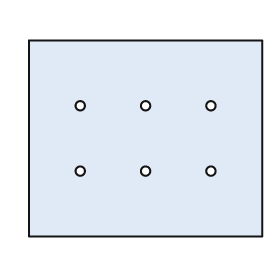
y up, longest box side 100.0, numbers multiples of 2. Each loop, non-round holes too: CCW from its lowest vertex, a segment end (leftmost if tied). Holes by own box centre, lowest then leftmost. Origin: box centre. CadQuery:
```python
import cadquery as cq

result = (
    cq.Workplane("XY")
    .moveTo(-50.0, -42.0)
    .lineTo(50.0, -42.0)
    .lineTo(50.0, 42.0)
    .lineTo(-50.0, 42.0)
    .close()
    .moveTo(-28.0, -14.0)
    .circle(2.0)
    .moveTo(0.0, -14.0)
    .circle(2.0)
    .moveTo(28.0, -14.0)
    .circle(2.0)
    .moveTo(-28.0, 14.0)
    .circle(2.0)
    .moveTo(0.0, 14.0)
    .circle(2.0)
    .moveTo(28.0, 14.0)
    .circle(2.0)
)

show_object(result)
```